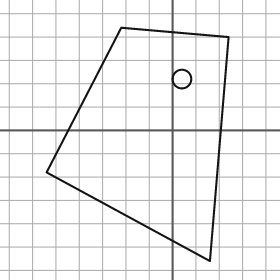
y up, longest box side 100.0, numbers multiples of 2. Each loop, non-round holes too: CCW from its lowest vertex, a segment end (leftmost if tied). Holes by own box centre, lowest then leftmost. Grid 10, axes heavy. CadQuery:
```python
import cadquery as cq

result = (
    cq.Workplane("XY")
    .moveTo(16.0, -56.0)
    .lineTo(24.0, 40.0)
    .lineTo(-22.0, 44.0)
    .lineTo(-54.0, -18.0)
    .close()
    .moveTo(4.0, 22.0)
    .circle(4.0)
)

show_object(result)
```